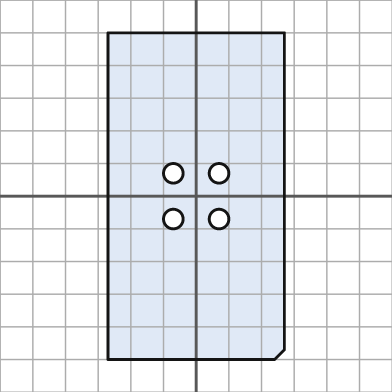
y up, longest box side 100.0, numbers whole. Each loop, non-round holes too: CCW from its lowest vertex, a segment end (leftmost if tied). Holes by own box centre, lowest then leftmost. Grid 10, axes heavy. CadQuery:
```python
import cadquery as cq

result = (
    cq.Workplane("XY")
    .moveTo(-27.0, -50.0)
    .lineTo(24.0, -50.0)
    .lineTo(27.0, -47.0)
    .lineTo(27.0, 50.0)
    .lineTo(-27.0, 50.0)
    .close()
    .moveTo(-7.0, -7.0)
    .circle(3.0)
    .moveTo(7.0, -7.0)
    .circle(3.0)
    .moveTo(-7.0, 7.0)
    .circle(3.0)
    .moveTo(7.0, 7.0)
    .circle(3.0)
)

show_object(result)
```